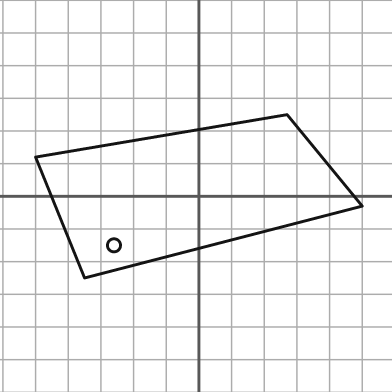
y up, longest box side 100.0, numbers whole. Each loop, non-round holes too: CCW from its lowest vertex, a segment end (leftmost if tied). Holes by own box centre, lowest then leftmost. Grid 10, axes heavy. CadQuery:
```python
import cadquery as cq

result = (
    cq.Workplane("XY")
    .moveTo(-35.0, -25.0)
    .lineTo(50.0, -3.0)
    .lineTo(27.0, 25.0)
    .lineTo(-50.0, 12.0)
    .close()
    .moveTo(-26.0, -15.0)
    .circle(2.0)
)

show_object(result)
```